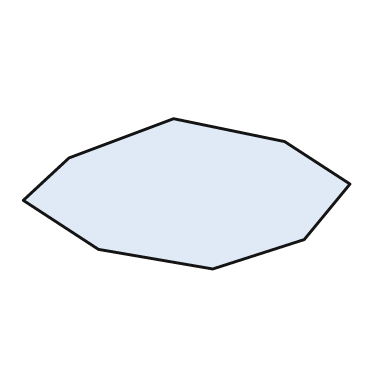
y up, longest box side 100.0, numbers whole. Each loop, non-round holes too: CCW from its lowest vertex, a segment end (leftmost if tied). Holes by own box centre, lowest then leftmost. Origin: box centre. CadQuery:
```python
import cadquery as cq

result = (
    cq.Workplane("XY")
    .moveTo(8.0, -23.0)
    .lineTo(36.0, -14.0)
    .lineTo(50.0, 3.0)
    .lineTo(30.0, 16.0)
    .lineTo(-4.0, 23.0)
    .lineTo(-36.0, 11.0)
    .lineTo(-50.0, -2.0)
    .lineTo(-27.0, -17.0)
    .close()
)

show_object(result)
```